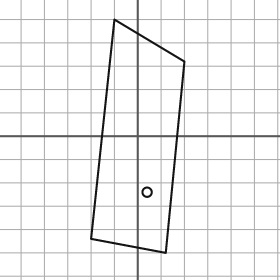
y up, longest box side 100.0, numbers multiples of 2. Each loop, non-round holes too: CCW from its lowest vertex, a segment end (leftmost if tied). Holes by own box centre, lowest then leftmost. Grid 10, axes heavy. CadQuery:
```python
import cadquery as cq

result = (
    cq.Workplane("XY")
    .moveTo(12.0, -50.0)
    .lineTo(20.0, 32.0)
    .lineTo(-10.0, 50.0)
    .lineTo(-20.0, -44.0)
    .close()
    .moveTo(4.0, -24.0)
    .circle(2.0)
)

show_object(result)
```